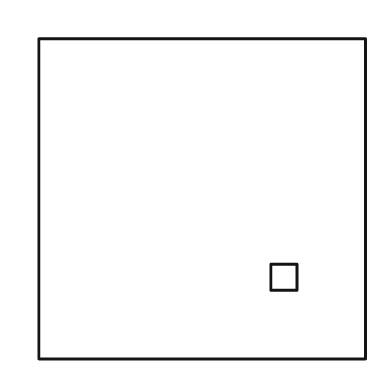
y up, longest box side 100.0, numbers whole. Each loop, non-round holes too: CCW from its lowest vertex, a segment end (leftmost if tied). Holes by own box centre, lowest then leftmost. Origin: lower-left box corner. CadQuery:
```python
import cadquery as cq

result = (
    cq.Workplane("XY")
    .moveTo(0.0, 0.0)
    .lineTo(100.0, 0.0)
    .lineTo(100.0, 98.0)
    .lineTo(0.0, 98.0)
    .close()
    .moveTo(71.0, 21.0)
    .lineTo(79.0, 21.0)
    .lineTo(79.0, 29.0)
    .lineTo(71.0, 29.0)
    .close()
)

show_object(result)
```